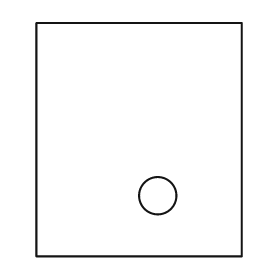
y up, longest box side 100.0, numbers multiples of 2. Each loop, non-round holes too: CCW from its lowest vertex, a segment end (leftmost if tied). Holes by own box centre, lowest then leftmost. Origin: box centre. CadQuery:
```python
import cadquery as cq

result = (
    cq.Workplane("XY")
    .moveTo(-44.0, -50.0)
    .lineTo(44.0, -50.0)
    .lineTo(44.0, 50.0)
    .lineTo(-44.0, 50.0)
    .close()
    .moveTo(8.0, -24.0)
    .circle(8.0)
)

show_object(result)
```